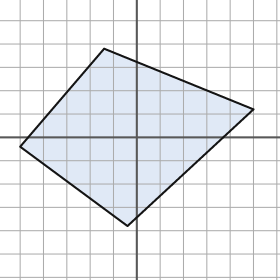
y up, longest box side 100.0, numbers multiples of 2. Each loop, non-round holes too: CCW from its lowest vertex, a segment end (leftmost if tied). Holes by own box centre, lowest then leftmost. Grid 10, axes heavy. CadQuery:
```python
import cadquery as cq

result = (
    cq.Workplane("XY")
    .moveTo(-4.0, -38.0)
    .lineTo(50.0, 12.0)
    .lineTo(-14.0, 38.0)
    .lineTo(-50.0, -4.0)
    .close()
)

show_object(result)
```